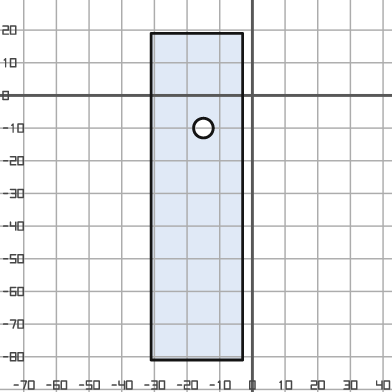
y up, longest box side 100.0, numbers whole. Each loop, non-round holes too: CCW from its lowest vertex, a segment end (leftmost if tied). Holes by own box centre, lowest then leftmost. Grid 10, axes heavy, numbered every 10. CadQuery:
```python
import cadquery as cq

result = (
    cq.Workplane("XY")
    .moveTo(-31.0, -81.0)
    .lineTo(-3.0, -81.0)
    .lineTo(-3.0, 19.0)
    .lineTo(-31.0, 19.0)
    .close()
    .moveTo(-15.0, -10.0)
    .circle(3.0)
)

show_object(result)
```